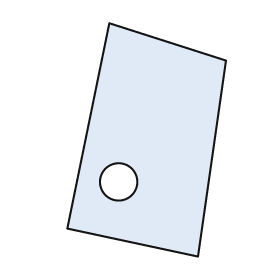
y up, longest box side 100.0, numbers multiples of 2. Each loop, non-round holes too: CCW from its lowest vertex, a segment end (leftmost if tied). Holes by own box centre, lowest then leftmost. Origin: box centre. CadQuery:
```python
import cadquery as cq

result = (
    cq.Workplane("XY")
    .moveTo(22.0, -50.0)
    .lineTo(34.0, 34.0)
    .lineTo(-16.0, 50.0)
    .lineTo(-34.0, -38.0)
    .close()
    .moveTo(-12.0, -18.0)
    .circle(8.0)
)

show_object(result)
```